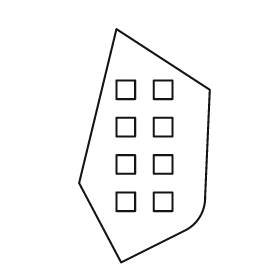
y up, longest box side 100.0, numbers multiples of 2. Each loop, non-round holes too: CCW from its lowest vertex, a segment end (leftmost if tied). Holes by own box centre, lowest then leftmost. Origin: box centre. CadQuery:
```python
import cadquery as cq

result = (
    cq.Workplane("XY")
    .moveTo(-10.0, -50.0)
    .lineTo(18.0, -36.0)
    .threePointArc((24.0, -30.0), (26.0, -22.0))
    .lineTo(28.0, 24.0)
    .lineTo(-12.0, 50.0)
    .lineTo(-28.0, -16.0)
    .close()
    .moveTo(-12.0, -28.0)
    .lineTo(-4.0, -28.0)
    .lineTo(-4.0, -20.0)
    .lineTo(-12.0, -20.0)
    .close()
    .moveTo(4.0, -28.0)
    .lineTo(12.0, -28.0)
    .lineTo(12.0, -20.0)
    .lineTo(4.0, -20.0)
    .close()
    .moveTo(-12.0, -12.0)
    .lineTo(-4.0, -12.0)
    .lineTo(-4.0, -4.0)
    .lineTo(-12.0, -4.0)
    .close()
    .moveTo(4.0, -12.0)
    .lineTo(12.0, -12.0)
    .lineTo(12.0, -4.0)
    .lineTo(4.0, -4.0)
    .close()
    .moveTo(-12.0, 4.0)
    .lineTo(-4.0, 4.0)
    .lineTo(-4.0, 12.0)
    .lineTo(-12.0, 12.0)
    .close()
    .moveTo(4.0, 4.0)
    .lineTo(12.0, 4.0)
    .lineTo(12.0, 12.0)
    .lineTo(4.0, 12.0)
    .close()
    .moveTo(-12.0, 20.0)
    .lineTo(-4.0, 20.0)
    .lineTo(-4.0, 28.0)
    .lineTo(-12.0, 28.0)
    .close()
    .moveTo(4.0, 20.0)
    .lineTo(12.0, 20.0)
    .lineTo(12.0, 28.0)
    .lineTo(4.0, 28.0)
    .close()
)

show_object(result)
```